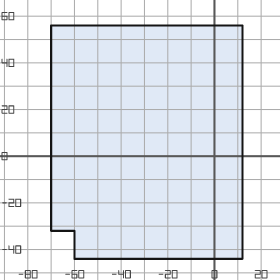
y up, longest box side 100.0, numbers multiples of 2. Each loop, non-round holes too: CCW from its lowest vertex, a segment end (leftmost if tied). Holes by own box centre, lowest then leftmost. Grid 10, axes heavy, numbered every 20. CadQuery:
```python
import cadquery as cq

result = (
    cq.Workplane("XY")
    .moveTo(-60.0, -44.0)
    .lineTo(12.0, -44.0)
    .lineTo(12.0, 56.0)
    .lineTo(-70.0, 56.0)
    .lineTo(-70.0, -32.0)
    .lineTo(-60.0, -32.0)
    .close()
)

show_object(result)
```